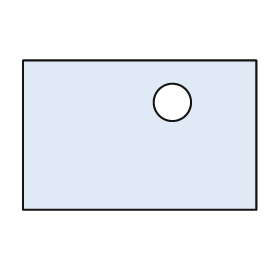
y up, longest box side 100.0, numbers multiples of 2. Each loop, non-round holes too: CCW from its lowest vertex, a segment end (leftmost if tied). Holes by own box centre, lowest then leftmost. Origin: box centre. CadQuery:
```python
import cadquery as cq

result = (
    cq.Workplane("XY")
    .moveTo(-50.0, -32.0)
    .lineTo(50.0, -32.0)
    .lineTo(50.0, 32.0)
    .lineTo(-50.0, 32.0)
    .close()
    .moveTo(14.0, 14.0)
    .circle(8.0)
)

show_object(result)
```